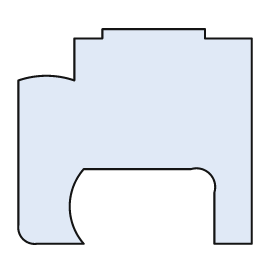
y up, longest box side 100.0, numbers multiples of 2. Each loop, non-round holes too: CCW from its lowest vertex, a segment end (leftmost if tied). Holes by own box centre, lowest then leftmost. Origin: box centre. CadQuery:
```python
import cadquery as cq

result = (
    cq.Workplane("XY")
    .moveTo(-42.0, -46.0)
    .lineTo(-22.0, -46.0)
    .threePointArc((-28.0, -30.0), (-22.0, -14.0))
    .lineTo(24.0, -14.0)
    .threePointArc((32.0, -16.0), (34.0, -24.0))
    .lineTo(34.0, -46.0)
    .lineTo(50.0, -46.0)
    .lineTo(50.0, 42.0)
    .lineTo(30.0, 42.0)
    .lineTo(30.0, 46.0)
    .lineTo(-14.0, 46.0)
    .lineTo(-14.0, 42.0)
    .lineTo(-26.0, 42.0)
    .lineTo(-26.0, 24.0)
    .threePointArc((-38.0, 26.0), (-50.0, 24.0))
    .lineTo(-50.0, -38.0)
    .threePointArc((-48.0, -44.0), (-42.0, -46.0))
    .close()
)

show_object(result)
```